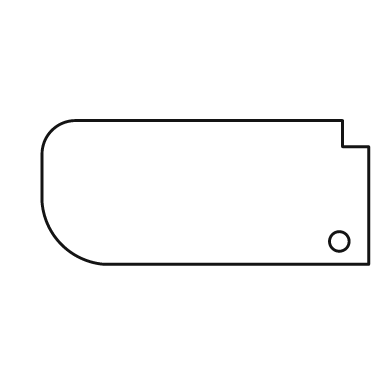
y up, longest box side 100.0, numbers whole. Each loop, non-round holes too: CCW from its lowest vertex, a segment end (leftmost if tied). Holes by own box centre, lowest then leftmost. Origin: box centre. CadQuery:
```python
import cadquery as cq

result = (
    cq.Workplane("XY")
    .moveTo(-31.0, -22.0)
    .lineTo(50.0, -22.0)
    .lineTo(50.0, 14.0)
    .lineTo(42.0, 14.0)
    .lineTo(42.0, 22.0)
    .lineTo(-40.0, 22.0)
    .threePointArc((-47.0, 19.0), (-50.0, 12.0))
    .lineTo(-50.0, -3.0)
    .threePointArc((-44.0, -16.0), (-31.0, -22.0))
    .close()
    .moveTo(41.0, -15.0)
    .circle(3.0)
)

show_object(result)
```